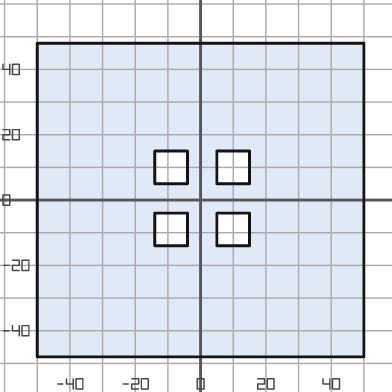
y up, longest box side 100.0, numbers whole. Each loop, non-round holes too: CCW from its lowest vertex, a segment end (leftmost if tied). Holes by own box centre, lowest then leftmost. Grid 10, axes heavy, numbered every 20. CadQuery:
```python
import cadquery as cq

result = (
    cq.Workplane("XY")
    .moveTo(-50.0, -48.0)
    .lineTo(50.0, -48.0)
    .lineTo(50.0, 48.0)
    .lineTo(-50.0, 48.0)
    .close()
    .moveTo(-14.0, -14.0)
    .lineTo(-4.0, -14.0)
    .lineTo(-4.0, -4.0)
    .lineTo(-14.0, -4.0)
    .close()
    .moveTo(5.0, -14.0)
    .lineTo(15.0, -14.0)
    .lineTo(15.0, -4.0)
    .lineTo(5.0, -4.0)
    .close()
    .moveTo(-14.0, 5.0)
    .lineTo(-4.0, 5.0)
    .lineTo(-4.0, 15.0)
    .lineTo(-14.0, 15.0)
    .close()
    .moveTo(5.0, 5.0)
    .lineTo(15.0, 5.0)
    .lineTo(15.0, 15.0)
    .lineTo(5.0, 15.0)
    .close()
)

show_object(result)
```